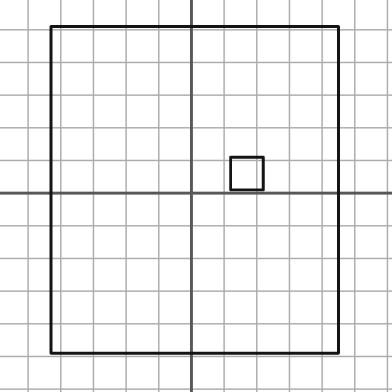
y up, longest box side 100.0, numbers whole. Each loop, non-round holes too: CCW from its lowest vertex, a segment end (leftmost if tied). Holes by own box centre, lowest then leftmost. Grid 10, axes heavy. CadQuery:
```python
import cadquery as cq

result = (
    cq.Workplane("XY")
    .moveTo(-43.0, -49.0)
    .lineTo(45.0, -49.0)
    .lineTo(45.0, 51.0)
    .lineTo(-43.0, 51.0)
    .close()
    .moveTo(12.0, 1.0)
    .lineTo(22.0, 1.0)
    .lineTo(22.0, 11.0)
    .lineTo(12.0, 11.0)
    .close()
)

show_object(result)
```